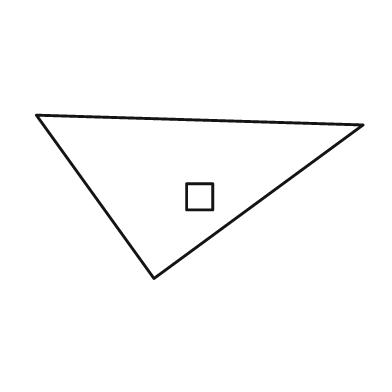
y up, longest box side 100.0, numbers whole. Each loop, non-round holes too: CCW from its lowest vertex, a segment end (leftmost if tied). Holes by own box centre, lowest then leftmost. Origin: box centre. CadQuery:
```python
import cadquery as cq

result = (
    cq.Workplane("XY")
    .moveTo(-14.0, -25.0)
    .lineTo(50.0, 22.0)
    .lineTo(-50.0, 25.0)
    .close()
    .moveTo(-4.0, -4.0)
    .lineTo(4.0, -4.0)
    .lineTo(4.0, 4.0)
    .lineTo(-4.0, 4.0)
    .close()
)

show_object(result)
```